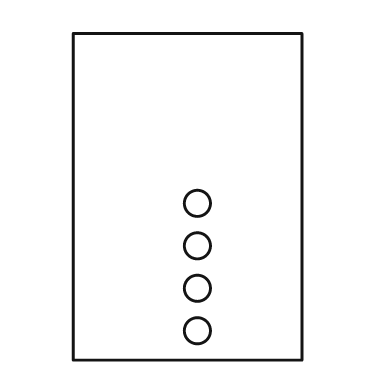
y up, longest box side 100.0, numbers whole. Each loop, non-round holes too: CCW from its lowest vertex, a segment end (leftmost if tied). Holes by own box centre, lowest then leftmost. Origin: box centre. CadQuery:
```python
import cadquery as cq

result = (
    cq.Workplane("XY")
    .moveTo(-35.0, -50.0)
    .lineTo(35.0, -50.0)
    .lineTo(35.0, 50.0)
    .lineTo(-35.0, 50.0)
    .close()
    .moveTo(3.0, -41.0)
    .circle(4.0)
    .moveTo(3.0, -28.0)
    .circle(4.0)
    .moveTo(3.0, -15.0)
    .circle(4.0)
    .moveTo(3.0, -2.0)
    .circle(4.0)
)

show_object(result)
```